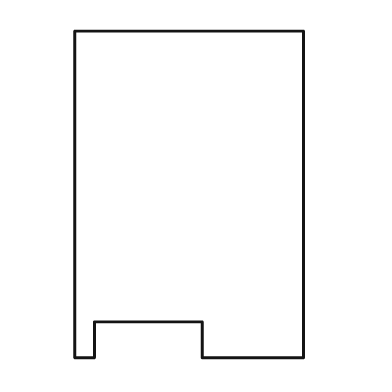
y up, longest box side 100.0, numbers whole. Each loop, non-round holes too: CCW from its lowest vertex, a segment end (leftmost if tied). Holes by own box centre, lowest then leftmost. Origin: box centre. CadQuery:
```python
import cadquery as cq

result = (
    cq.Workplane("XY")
    .moveTo(-35.0, -50.0)
    .lineTo(-29.0, -50.0)
    .lineTo(-29.0, -39.0)
    .lineTo(4.0, -39.0)
    .lineTo(4.0, -50.0)
    .lineTo(35.0, -50.0)
    .lineTo(35.0, 50.0)
    .lineTo(-35.0, 50.0)
    .close()
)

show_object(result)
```